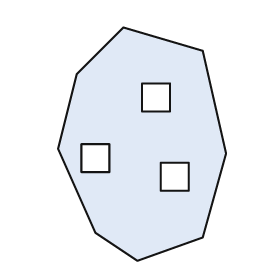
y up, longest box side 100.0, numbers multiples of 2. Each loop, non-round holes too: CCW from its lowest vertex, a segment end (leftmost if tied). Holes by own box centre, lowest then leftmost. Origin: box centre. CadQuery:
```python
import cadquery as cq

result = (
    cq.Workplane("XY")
    .moveTo(-2.0, -50.0)
    .lineTo(26.0, -40.0)
    .lineTo(36.0, -4.0)
    .lineTo(26.0, 40.0)
    .lineTo(-8.0, 50.0)
    .lineTo(-28.0, 30.0)
    .lineTo(-36.0, -2.0)
    .lineTo(-20.0, -38.0)
    .close()
    .moveTo(8.0, -20.0)
    .lineTo(20.0, -20.0)
    .lineTo(20.0, -8.0)
    .lineTo(8.0, -8.0)
    .close()
    .moveTo(-26.0, -12.0)
    .lineTo(-14.0, -12.0)
    .lineTo(-14.0, 0.0)
    .lineTo(-26.0, 0.0)
    .close()
    .moveTo(0.0, 14.0)
    .lineTo(12.0, 14.0)
    .lineTo(12.0, 26.0)
    .lineTo(0.0, 26.0)
    .close()
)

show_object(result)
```